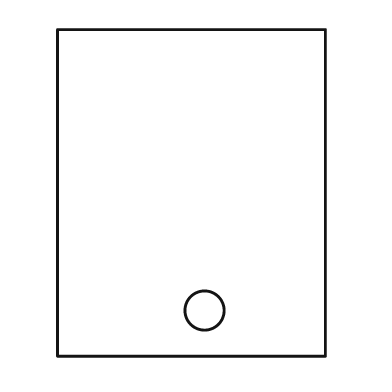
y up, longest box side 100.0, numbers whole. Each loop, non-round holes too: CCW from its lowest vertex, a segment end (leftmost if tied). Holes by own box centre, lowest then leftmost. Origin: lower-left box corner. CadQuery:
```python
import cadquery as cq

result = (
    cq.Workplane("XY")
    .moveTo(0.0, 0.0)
    .lineTo(82.0, 0.0)
    .lineTo(82.0, 100.0)
    .lineTo(0.0, 100.0)
    .close()
    .moveTo(45.0, 14.0)
    .circle(6.0)
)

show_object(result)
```